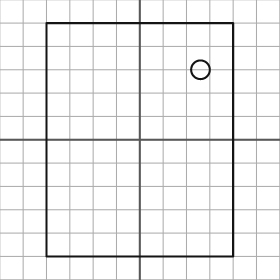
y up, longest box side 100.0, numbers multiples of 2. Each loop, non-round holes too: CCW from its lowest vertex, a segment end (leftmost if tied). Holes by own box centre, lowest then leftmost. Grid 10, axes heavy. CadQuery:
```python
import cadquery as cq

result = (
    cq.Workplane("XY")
    .moveTo(-40.0, -50.0)
    .lineTo(40.0, -50.0)
    .lineTo(40.0, 50.0)
    .lineTo(-40.0, 50.0)
    .close()
    .moveTo(26.0, 30.0)
    .circle(4.0)
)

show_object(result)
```